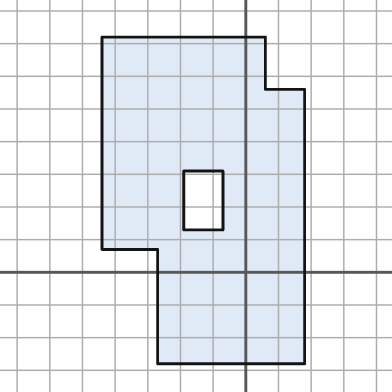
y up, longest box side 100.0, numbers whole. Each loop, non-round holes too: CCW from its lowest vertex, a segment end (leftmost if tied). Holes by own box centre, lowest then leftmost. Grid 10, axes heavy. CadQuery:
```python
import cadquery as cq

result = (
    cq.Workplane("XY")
    .moveTo(-27.0, -28.0)
    .lineTo(18.0, -28.0)
    .lineTo(18.0, 56.0)
    .lineTo(6.0, 56.0)
    .lineTo(6.0, 72.0)
    .lineTo(-44.0, 72.0)
    .lineTo(-44.0, 7.0)
    .lineTo(-27.0, 7.0)
    .close()
    .moveTo(-19.0, 13.0)
    .lineTo(-7.0, 13.0)
    .lineTo(-7.0, 31.0)
    .lineTo(-19.0, 31.0)
    .close()
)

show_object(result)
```